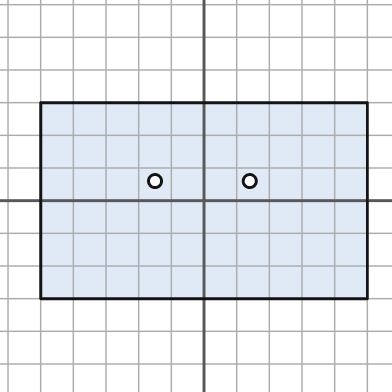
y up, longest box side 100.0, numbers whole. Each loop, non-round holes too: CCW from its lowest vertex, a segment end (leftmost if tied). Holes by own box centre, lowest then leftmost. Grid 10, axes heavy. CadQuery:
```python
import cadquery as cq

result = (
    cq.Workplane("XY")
    .moveTo(-50.0, -30.0)
    .lineTo(50.0, -30.0)
    .lineTo(50.0, 30.0)
    .lineTo(-50.0, 30.0)
    .close()
    .moveTo(-15.0, 6.0)
    .circle(2.0)
    .moveTo(14.0, 6.0)
    .circle(2.0)
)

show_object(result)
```